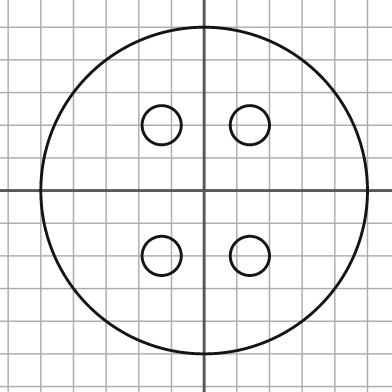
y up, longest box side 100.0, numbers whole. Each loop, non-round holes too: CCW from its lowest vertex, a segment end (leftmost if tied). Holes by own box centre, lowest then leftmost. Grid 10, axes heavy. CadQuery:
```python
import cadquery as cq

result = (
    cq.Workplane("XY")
    .moveTo(0.0, 0.0)
    .circle(50.0)
    .moveTo(-13.0, -20.0)
    .circle(6.0)
    .moveTo(14.0, -20.0)
    .circle(6.0)
    .moveTo(-13.0, 20.0)
    .circle(6.0)
    .moveTo(14.0, 20.0)
    .circle(6.0)
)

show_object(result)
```